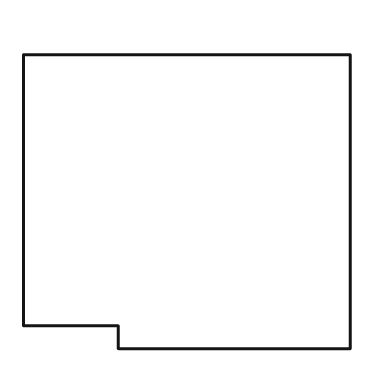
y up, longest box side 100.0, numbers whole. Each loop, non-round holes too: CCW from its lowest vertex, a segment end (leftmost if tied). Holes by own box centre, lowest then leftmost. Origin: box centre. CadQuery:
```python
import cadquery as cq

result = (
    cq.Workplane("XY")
    .moveTo(-21.0, -45.0)
    .lineTo(50.0, -45.0)
    .lineTo(50.0, 45.0)
    .lineTo(-50.0, 45.0)
    .lineTo(-50.0, -38.0)
    .lineTo(-21.0, -38.0)
    .close()
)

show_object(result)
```